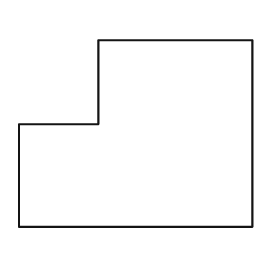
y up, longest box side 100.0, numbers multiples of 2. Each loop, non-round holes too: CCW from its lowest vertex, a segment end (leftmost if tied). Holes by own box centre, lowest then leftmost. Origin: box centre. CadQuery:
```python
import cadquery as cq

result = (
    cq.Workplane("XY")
    .moveTo(-50.0, -40.0)
    .lineTo(50.0, -40.0)
    .lineTo(50.0, 40.0)
    .lineTo(-16.0, 40.0)
    .lineTo(-16.0, 4.0)
    .lineTo(-50.0, 4.0)
    .close()
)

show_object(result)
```